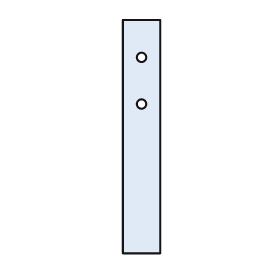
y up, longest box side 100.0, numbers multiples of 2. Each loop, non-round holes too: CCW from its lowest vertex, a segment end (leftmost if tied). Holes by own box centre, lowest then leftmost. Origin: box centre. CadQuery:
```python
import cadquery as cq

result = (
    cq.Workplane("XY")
    .moveTo(-8.0, -50.0)
    .lineTo(8.0, -50.0)
    .lineTo(8.0, 50.0)
    .lineTo(-8.0, 50.0)
    .close()
    .moveTo(0.0, 14.0)
    .circle(2.0)
    .moveTo(0.0, 34.0)
    .circle(2.0)
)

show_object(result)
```